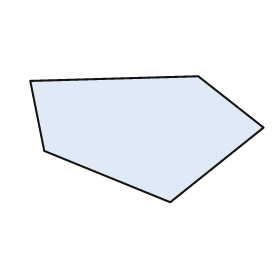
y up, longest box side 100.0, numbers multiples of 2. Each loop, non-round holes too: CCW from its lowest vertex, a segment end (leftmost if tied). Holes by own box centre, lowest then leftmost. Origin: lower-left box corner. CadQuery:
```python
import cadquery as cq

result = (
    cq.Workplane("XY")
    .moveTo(60.0, 0.0)
    .lineTo(100.0, 32.0)
    .lineTo(72.0, 54.0)
    .lineTo(0.0, 52.0)
    .lineTo(6.0, 22.0)
    .close()
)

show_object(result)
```